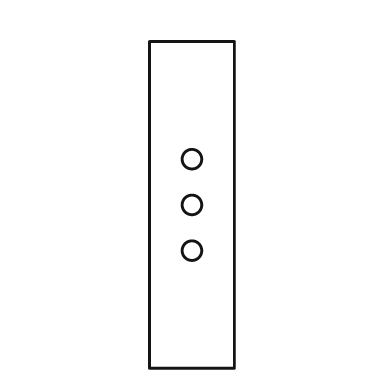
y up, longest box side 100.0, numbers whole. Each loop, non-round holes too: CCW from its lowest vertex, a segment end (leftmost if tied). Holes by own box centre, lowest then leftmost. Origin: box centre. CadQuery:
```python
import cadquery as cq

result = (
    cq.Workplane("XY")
    .moveTo(-13.0, -50.0)
    .lineTo(13.0, -50.0)
    .lineTo(13.0, 50.0)
    .lineTo(-13.0, 50.0)
    .close()
    .moveTo(0.0, -14.0)
    .circle(3.0)
    .moveTo(0.0, 0.0)
    .circle(3.0)
    .moveTo(0.0, 14.0)
    .circle(3.0)
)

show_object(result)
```